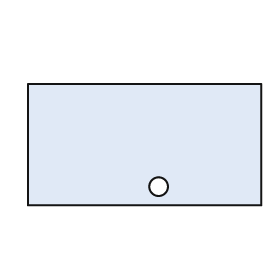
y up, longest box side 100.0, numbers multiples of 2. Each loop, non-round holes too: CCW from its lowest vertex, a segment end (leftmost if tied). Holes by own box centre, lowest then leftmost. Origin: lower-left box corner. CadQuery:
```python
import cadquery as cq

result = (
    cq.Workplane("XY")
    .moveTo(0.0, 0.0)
    .lineTo(100.0, 0.0)
    .lineTo(100.0, 52.0)
    .lineTo(0.0, 52.0)
    .close()
    .moveTo(56.0, 8.0)
    .circle(4.0)
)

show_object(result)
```